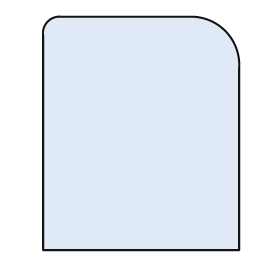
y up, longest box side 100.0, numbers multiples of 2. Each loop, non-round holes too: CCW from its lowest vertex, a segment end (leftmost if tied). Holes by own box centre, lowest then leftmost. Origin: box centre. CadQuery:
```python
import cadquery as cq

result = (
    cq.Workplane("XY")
    .moveTo(-42.0, -50.0)
    .lineTo(42.0, -50.0)
    .lineTo(42.0, 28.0)
    .threePointArc((36.0, 44.0), (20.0, 50.0))
    .lineTo(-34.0, 50.0)
    .threePointArc((-40.0, 48.0), (-42.0, 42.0))
    .close()
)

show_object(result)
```